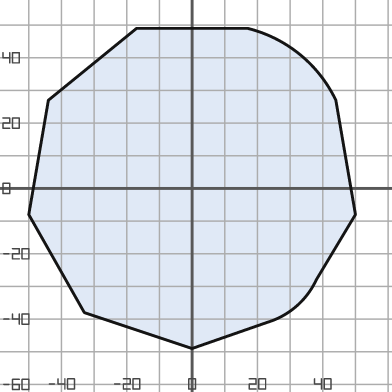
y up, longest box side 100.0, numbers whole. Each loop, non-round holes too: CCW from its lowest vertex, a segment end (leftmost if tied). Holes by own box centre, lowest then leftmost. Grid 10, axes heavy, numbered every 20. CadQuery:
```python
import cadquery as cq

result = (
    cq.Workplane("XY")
    .moveTo(0.0, -49.0)
    .lineTo(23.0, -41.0)
    .threePointArc((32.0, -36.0), (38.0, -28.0))
    .lineTo(50.0, -8.0)
    .lineTo(44.0, 27.0)
    .threePointArc((33.0, 41.0), (17.0, 49.0))
    .lineTo(-17.0, 49.0)
    .lineTo(-44.0, 27.0)
    .lineTo(-50.0, -8.0)
    .lineTo(-33.0, -38.0)
    .close()
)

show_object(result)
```